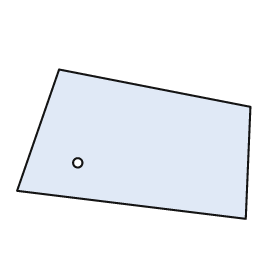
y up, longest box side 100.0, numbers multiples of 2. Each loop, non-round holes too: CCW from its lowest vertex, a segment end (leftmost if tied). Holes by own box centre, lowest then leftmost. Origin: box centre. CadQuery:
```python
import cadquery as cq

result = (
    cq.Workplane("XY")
    .moveTo(48.0, -32.0)
    .lineTo(50.0, 16.0)
    .lineTo(-32.0, 32.0)
    .lineTo(-50.0, -20.0)
    .close()
    .moveTo(-24.0, -8.0)
    .circle(2.0)
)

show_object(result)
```